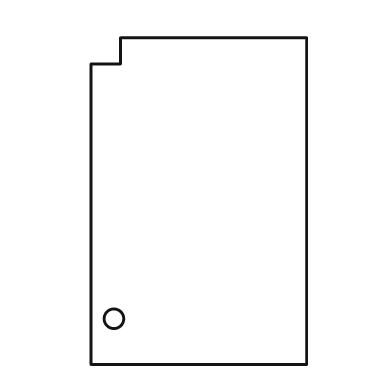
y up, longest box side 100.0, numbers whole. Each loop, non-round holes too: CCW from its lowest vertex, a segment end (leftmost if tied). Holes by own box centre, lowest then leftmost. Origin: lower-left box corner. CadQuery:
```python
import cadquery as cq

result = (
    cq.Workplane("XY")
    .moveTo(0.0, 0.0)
    .lineTo(66.0, 0.0)
    .lineTo(66.0, 100.0)
    .lineTo(9.0, 100.0)
    .lineTo(9.0, 92.0)
    .lineTo(0.0, 92.0)
    .close()
    .moveTo(7.0, 14.0)
    .circle(3.0)
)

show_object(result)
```